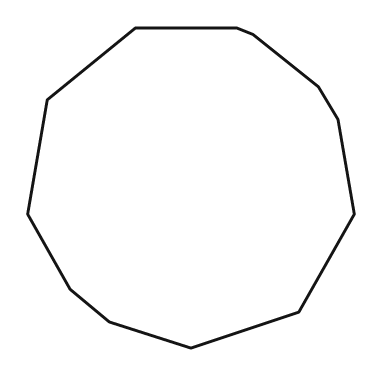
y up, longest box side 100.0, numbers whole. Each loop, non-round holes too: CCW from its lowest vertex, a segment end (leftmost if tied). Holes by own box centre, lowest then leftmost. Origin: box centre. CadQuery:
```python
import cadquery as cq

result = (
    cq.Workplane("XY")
    .moveTo(0.0, -49.0)
    .lineTo(33.0, -38.0)
    .lineTo(50.0, -8.0)
    .lineTo(45.0, 21.0)
    .lineTo(39.0, 31.0)
    .lineTo(19.0, 47.0)
    .lineTo(14.0, 49.0)
    .lineTo(-17.0, 49.0)
    .lineTo(-44.0, 27.0)
    .lineTo(-50.0, -8.0)
    .lineTo(-37.0, -31.0)
    .lineTo(-25.0, -41.0)
    .close()
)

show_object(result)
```